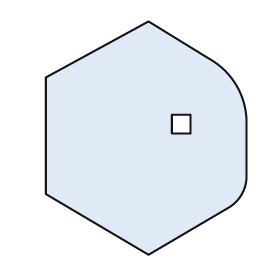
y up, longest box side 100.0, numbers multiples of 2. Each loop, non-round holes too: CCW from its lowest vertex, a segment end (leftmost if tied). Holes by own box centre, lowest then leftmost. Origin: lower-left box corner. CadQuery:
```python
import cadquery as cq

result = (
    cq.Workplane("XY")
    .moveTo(44.0, 0.0)
    .lineTo(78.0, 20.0)
    .threePointArc((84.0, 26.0), (86.0, 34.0))
    .lineTo(86.0, 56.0)
    .threePointArc((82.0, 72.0), (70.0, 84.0))
    .lineTo(44.0, 100.0)
    .lineTo(0.0, 76.0)
    .lineTo(0.0, 26.0)
    .close()
    .moveTo(54.0, 52.0)
    .lineTo(62.0, 52.0)
    .lineTo(62.0, 60.0)
    .lineTo(54.0, 60.0)
    .close()
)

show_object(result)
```